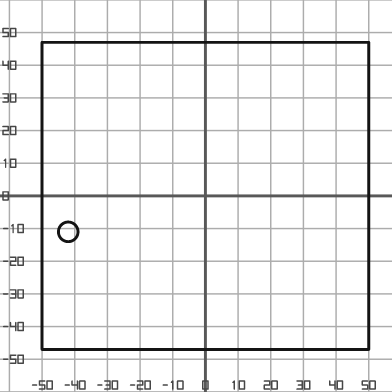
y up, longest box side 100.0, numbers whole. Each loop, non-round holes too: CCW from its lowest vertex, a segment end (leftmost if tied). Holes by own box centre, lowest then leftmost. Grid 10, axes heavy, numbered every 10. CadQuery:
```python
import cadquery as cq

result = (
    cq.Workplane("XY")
    .moveTo(-50.0, -47.0)
    .lineTo(50.0, -47.0)
    .lineTo(50.0, 47.0)
    .lineTo(-50.0, 47.0)
    .close()
    .moveTo(-42.0, -11.0)
    .circle(3.0)
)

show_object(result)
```